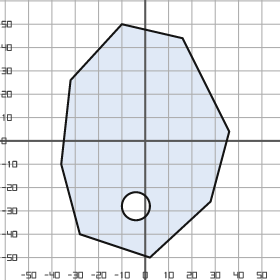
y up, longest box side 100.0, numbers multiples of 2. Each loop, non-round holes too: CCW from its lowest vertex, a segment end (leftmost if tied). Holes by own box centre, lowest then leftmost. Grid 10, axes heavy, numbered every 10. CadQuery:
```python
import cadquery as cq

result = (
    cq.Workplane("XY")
    .moveTo(2.0, -50.0)
    .lineTo(28.0, -26.0)
    .lineTo(36.0, 4.0)
    .lineTo(16.0, 44.0)
    .lineTo(-10.0, 50.0)
    .lineTo(-32.0, 26.0)
    .lineTo(-36.0, -10.0)
    .lineTo(-28.0, -40.0)
    .close()
    .moveTo(-4.0, -28.0)
    .circle(6.0)
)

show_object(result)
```